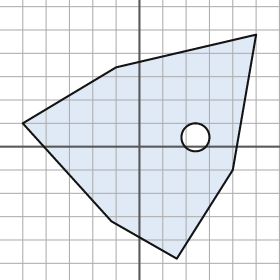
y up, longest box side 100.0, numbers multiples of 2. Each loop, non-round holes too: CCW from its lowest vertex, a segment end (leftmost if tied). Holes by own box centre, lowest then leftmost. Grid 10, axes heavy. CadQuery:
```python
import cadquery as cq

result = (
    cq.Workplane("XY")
    .moveTo(16.0, -48.0)
    .lineTo(40.0, -10.0)
    .lineTo(50.0, 48.0)
    .lineTo(-10.0, 34.0)
    .lineTo(-50.0, 10.0)
    .lineTo(-12.0, -32.0)
    .close()
    .moveTo(24.0, 4.0)
    .circle(6.0)
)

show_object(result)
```